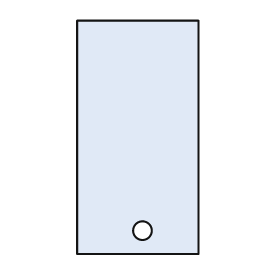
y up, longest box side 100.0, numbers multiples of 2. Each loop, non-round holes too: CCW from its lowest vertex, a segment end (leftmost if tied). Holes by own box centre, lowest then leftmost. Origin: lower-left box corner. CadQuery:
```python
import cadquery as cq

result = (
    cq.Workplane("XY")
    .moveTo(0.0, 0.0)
    .lineTo(52.0, 0.0)
    .lineTo(52.0, 100.0)
    .lineTo(0.0, 100.0)
    .close()
    .moveTo(28.0, 10.0)
    .circle(4.0)
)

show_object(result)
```